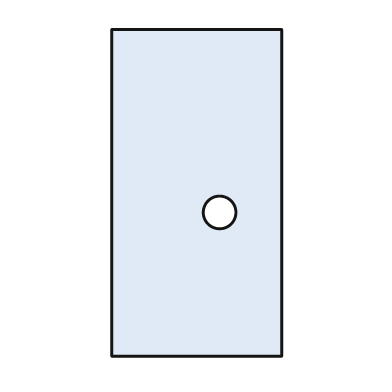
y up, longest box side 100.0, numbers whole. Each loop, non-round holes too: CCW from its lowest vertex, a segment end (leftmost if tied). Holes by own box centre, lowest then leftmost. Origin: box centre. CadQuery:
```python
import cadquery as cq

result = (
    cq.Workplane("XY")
    .moveTo(-26.0, -50.0)
    .lineTo(26.0, -50.0)
    .lineTo(26.0, 50.0)
    .lineTo(-26.0, 50.0)
    .close()
    .moveTo(7.0, -6.0)
    .circle(5.0)
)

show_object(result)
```